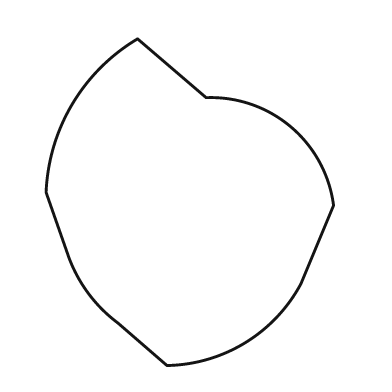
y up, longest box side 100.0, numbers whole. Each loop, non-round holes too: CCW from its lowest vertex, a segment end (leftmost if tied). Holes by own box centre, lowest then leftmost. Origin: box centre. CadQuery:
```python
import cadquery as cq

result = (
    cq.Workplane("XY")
    .moveTo(-7.0, -50.0)
    .threePointArc((17.0, -43.0), (34.0, -25.0))
    .lineTo(44.0, -1.0)
    .threePointArc((31.0, 23.0), (5.0, 32.0))
    .lineTo(-16.0, 50.0)
    .threePointArc((-36.0, 30.0), (-44.0, 3.0))
    .lineTo(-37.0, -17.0)
    .threePointArc((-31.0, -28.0), (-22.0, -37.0))
    .close()
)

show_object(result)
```